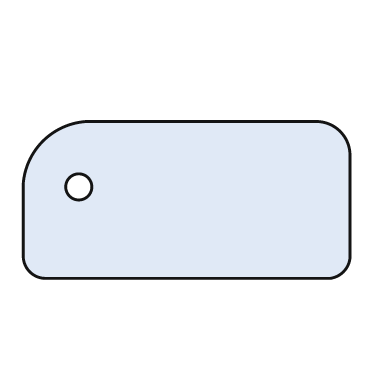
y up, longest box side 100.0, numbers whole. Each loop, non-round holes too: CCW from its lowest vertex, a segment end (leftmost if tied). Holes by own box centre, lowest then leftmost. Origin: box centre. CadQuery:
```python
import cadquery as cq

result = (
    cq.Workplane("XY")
    .moveTo(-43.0, -24.0)
    .lineTo(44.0, -24.0)
    .threePointArc((48.0, -22.0), (50.0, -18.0))
    .lineTo(50.0, 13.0)
    .threePointArc((47.0, 21.0), (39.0, 24.0))
    .lineTo(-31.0, 24.0)
    .threePointArc((-44.0, 18.0), (-50.0, 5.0))
    .lineTo(-50.0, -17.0)
    .threePointArc((-48.0, -22.0), (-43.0, -24.0))
    .close()
    .moveTo(-33.0, 4.0)
    .circle(4.0)
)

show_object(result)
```